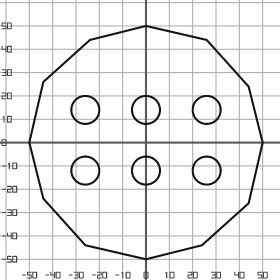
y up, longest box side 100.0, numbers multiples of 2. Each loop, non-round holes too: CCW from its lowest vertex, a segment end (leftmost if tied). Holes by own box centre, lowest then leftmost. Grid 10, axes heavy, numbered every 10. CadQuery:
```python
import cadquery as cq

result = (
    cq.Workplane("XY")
    .moveTo(0.0, -50.0)
    .lineTo(24.0, -44.0)
    .lineTo(44.0, -26.0)
    .lineTo(50.0, 0.0)
    .lineTo(44.0, 24.0)
    .lineTo(26.0, 44.0)
    .lineTo(0.0, 50.0)
    .lineTo(-24.0, 44.0)
    .lineTo(-44.0, 26.0)
    .lineTo(-50.0, 0.0)
    .lineTo(-44.0, -24.0)
    .lineTo(-26.0, -44.0)
    .close()
    .moveTo(-26.0, -12.0)
    .circle(6.0)
    .moveTo(0.0, -12.0)
    .circle(6.0)
    .moveTo(26.0, -12.0)
    .circle(6.0)
    .moveTo(-26.0, 14.0)
    .circle(6.0)
    .moveTo(0.0, 14.0)
    .circle(6.0)
    .moveTo(26.0, 14.0)
    .circle(6.0)
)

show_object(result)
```